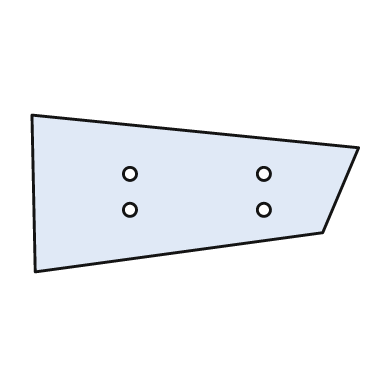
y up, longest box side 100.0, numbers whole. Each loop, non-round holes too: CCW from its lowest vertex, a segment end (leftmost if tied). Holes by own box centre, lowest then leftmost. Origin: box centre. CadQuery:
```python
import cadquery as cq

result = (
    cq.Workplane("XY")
    .moveTo(-49.0, -24.0)
    .lineTo(39.0, -12.0)
    .lineTo(50.0, 14.0)
    .lineTo(-50.0, 24.0)
    .close()
    .moveTo(-20.0, -5.0)
    .circle(2.0)
    .moveTo(21.0, -5.0)
    .circle(2.0)
    .moveTo(-20.0, 6.0)
    .circle(2.0)
    .moveTo(21.0, 6.0)
    .circle(2.0)
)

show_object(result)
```